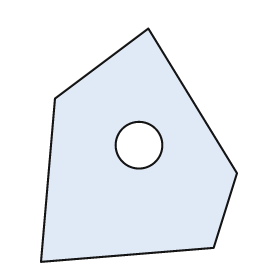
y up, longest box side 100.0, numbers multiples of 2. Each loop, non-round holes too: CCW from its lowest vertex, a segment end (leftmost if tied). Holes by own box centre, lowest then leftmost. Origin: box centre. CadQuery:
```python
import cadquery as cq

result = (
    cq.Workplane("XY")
    .moveTo(-42.0, -50.0)
    .lineTo(32.0, -44.0)
    .lineTo(42.0, -12.0)
    .lineTo(4.0, 50.0)
    .lineTo(-36.0, 20.0)
    .close()
    .moveTo(0.0, 0.0)
    .circle(10.0)
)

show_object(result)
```